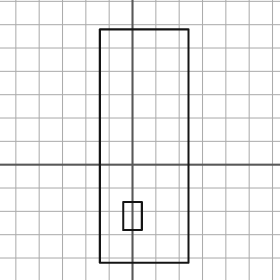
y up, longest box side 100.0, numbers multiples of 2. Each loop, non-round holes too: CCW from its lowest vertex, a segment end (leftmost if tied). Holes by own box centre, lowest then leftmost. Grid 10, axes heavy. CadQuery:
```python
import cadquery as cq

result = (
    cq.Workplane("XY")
    .moveTo(-14.0, -42.0)
    .lineTo(24.0, -42.0)
    .lineTo(24.0, 58.0)
    .lineTo(-14.0, 58.0)
    .close()
    .moveTo(-4.0, -28.0)
    .lineTo(4.0, -28.0)
    .lineTo(4.0, -16.0)
    .lineTo(-4.0, -16.0)
    .close()
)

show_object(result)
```